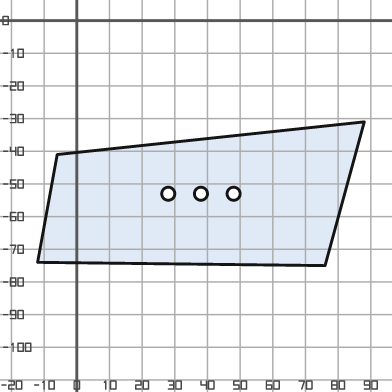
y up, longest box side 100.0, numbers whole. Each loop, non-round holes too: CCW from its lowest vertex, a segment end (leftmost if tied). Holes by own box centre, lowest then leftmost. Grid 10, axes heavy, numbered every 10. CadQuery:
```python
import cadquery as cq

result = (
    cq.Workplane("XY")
    .moveTo(76.0, -75.0)
    .lineTo(88.0, -31.0)
    .lineTo(-6.0, -41.0)
    .lineTo(-12.0, -74.0)
    .close()
    .moveTo(28.0, -53.0)
    .circle(2.0)
    .moveTo(38.0, -53.0)
    .circle(2.0)
    .moveTo(48.0, -53.0)
    .circle(2.0)
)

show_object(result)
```